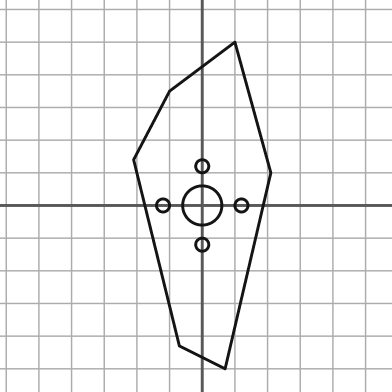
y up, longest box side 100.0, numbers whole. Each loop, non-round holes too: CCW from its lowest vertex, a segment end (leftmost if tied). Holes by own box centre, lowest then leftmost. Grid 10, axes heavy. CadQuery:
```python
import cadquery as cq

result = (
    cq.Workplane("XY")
    .moveTo(7.0, -50.0)
    .lineTo(21.0, 10.0)
    .lineTo(10.0, 50.0)
    .lineTo(-10.0, 35.0)
    .lineTo(-21.0, 14.0)
    .lineTo(-7.0, -43.0)
    .close()
    .moveTo(0.0, -12.0)
    .circle(2.0)
    .moveTo(-12.0, 0.0)
    .circle(2.0)
    .moveTo(0.0, 0.0)
    .circle(6.0)
    .moveTo(12.0, 0.0)
    .circle(2.0)
    .moveTo(0.0, 12.0)
    .circle(2.0)
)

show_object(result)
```